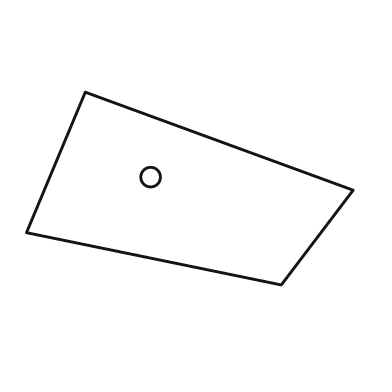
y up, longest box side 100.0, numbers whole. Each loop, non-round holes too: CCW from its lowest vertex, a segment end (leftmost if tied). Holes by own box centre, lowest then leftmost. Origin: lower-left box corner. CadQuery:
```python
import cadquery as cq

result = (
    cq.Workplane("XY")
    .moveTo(78.0, 0.0)
    .lineTo(100.0, 29.0)
    .lineTo(18.0, 59.0)
    .lineTo(0.0, 16.0)
    .close()
    .moveTo(38.0, 33.0)
    .circle(3.0)
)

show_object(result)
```